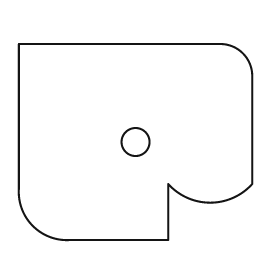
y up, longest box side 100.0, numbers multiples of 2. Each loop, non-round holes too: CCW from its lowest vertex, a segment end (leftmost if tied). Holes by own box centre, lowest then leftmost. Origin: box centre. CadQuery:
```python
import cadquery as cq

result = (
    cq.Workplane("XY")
    .moveTo(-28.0, -42.0)
    .lineTo(14.0, -42.0)
    .lineTo(14.0, -18.0)
    .threePointArc((32.0, -26.0), (50.0, -18.0))
    .lineTo(50.0, 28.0)
    .threePointArc((46.0, 38.0), (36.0, 42.0))
    .lineTo(-50.0, 42.0)
    .lineTo(-50.0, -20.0)
    .threePointArc((-44.0, -36.0), (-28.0, -42.0))
    .close()
    .moveTo(0.0, 0.0)
    .circle(6.0)
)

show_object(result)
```